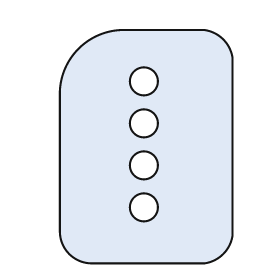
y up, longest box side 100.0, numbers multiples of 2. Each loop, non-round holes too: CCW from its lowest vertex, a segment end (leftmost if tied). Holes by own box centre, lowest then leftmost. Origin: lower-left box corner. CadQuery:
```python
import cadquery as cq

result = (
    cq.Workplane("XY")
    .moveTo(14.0, 0.0)
    .lineTo(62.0, 0.0)
    .threePointArc((70.0, 4.0), (74.0, 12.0))
    .lineTo(74.0, 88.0)
    .threePointArc((70.0, 96.0), (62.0, 100.0))
    .lineTo(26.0, 100.0)
    .threePointArc((8.0, 92.0), (0.0, 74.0))
    .lineTo(0.0, 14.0)
    .threePointArc((4.0, 4.0), (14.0, 0.0))
    .close()
    .moveTo(36.0, 24.0)
    .circle(6.0)
    .moveTo(36.0, 42.0)
    .circle(6.0)
    .moveTo(36.0, 60.0)
    .circle(6.0)
    .moveTo(36.0, 78.0)
    .circle(6.0)
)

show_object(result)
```